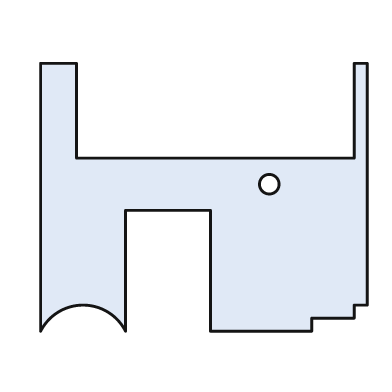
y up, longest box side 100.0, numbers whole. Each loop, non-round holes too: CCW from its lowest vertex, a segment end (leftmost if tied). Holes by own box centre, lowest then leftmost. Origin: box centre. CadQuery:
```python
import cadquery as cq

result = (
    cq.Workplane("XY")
    .moveTo(-50.0, -41.0)
    .threePointArc((-37.0, -33.0), (-24.0, -41.0))
    .lineTo(-24.0, -4.0)
    .lineTo(2.0, -4.0)
    .lineTo(2.0, -41.0)
    .lineTo(33.0, -41.0)
    .lineTo(33.0, -37.0)
    .lineTo(46.0, -37.0)
    .lineTo(46.0, -33.0)
    .lineTo(50.0, -33.0)
    .lineTo(50.0, 41.0)
    .lineTo(46.0, 41.0)
    .lineTo(46.0, 12.0)
    .lineTo(-39.0, 12.0)
    .lineTo(-39.0, 41.0)
    .lineTo(-50.0, 41.0)
    .close()
    .moveTo(20.0, 4.0)
    .circle(3.0)
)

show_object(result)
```